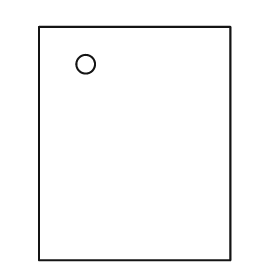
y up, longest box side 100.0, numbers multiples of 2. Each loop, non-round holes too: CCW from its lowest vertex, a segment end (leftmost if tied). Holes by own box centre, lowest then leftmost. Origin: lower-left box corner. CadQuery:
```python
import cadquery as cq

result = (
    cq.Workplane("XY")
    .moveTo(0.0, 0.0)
    .lineTo(82.0, 0.0)
    .lineTo(82.0, 100.0)
    .lineTo(0.0, 100.0)
    .close()
    .moveTo(20.0, 84.0)
    .circle(4.0)
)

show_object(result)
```